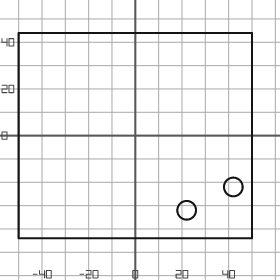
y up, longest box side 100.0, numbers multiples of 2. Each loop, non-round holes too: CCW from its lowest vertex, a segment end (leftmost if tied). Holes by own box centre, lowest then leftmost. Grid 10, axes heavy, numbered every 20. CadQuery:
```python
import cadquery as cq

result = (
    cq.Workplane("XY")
    .moveTo(-50.0, -44.0)
    .lineTo(50.0, -44.0)
    .lineTo(50.0, 44.0)
    .lineTo(-50.0, 44.0)
    .close()
    .moveTo(22.0, -32.0)
    .circle(4.0)
    .moveTo(42.0, -22.0)
    .circle(4.0)
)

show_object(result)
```